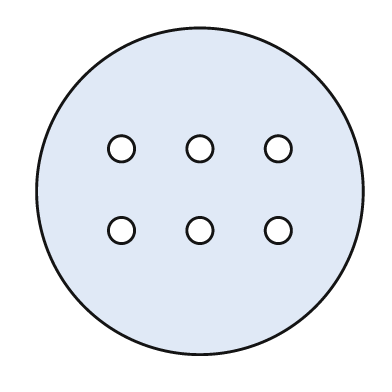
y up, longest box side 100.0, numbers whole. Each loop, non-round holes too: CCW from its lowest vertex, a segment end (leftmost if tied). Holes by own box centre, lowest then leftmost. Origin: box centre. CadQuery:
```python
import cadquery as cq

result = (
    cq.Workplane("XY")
    .moveTo(0.0, 0.0)
    .circle(50.0)
    .moveTo(-24.0, -12.0)
    .circle(4.0)
    .moveTo(0.0, -12.0)
    .circle(4.0)
    .moveTo(24.0, -12.0)
    .circle(4.0)
    .moveTo(-24.0, 13.0)
    .circle(4.0)
    .moveTo(0.0, 13.0)
    .circle(4.0)
    .moveTo(24.0, 13.0)
    .circle(4.0)
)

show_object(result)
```